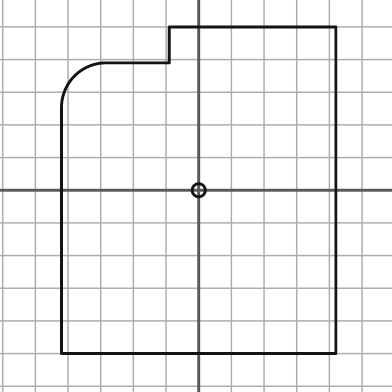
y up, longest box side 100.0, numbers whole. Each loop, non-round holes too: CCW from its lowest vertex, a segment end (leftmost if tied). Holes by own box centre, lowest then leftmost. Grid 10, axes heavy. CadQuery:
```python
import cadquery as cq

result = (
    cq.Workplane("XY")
    .moveTo(-42.0, -50.0)
    .lineTo(42.0, -50.0)
    .lineTo(42.0, 50.0)
    .lineTo(-9.0, 50.0)
    .lineTo(-9.0, 39.0)
    .lineTo(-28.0, 39.0)
    .threePointArc((-38.0, 35.0), (-42.0, 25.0))
    .close()
    .moveTo(0.0, 0.0)
    .circle(2.0)
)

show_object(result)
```